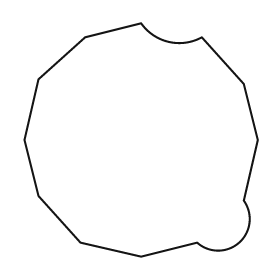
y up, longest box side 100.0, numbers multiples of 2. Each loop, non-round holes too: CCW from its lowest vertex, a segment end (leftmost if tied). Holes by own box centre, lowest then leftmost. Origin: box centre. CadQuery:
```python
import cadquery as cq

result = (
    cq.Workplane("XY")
    .moveTo(0.0, -50.0)
    .lineTo(24.0, -44.0)
    .threePointArc((42.0, -44.0), (44.0, -26.0))
    .lineTo(50.0, 0.0)
    .lineTo(44.0, 24.0)
    .lineTo(26.0, 44.0)
    .threePointArc((12.0, 42.0), (0.0, 50.0))
    .lineTo(-24.0, 44.0)
    .lineTo(-44.0, 26.0)
    .lineTo(-50.0, 0.0)
    .lineTo(-44.0, -24.0)
    .lineTo(-26.0, -44.0)
    .close()
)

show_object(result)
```